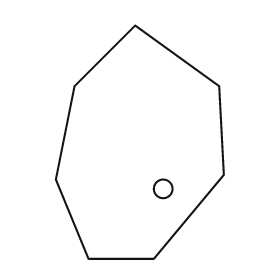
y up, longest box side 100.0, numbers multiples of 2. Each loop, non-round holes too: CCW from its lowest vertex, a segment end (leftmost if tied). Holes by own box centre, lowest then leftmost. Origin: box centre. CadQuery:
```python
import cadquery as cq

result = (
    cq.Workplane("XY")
    .moveTo(-22.0, -50.0)
    .lineTo(6.0, -50.0)
    .lineTo(36.0, -14.0)
    .lineTo(34.0, 24.0)
    .lineTo(-2.0, 50.0)
    .lineTo(-28.0, 24.0)
    .lineTo(-36.0, -16.0)
    .close()
    .moveTo(10.0, -20.0)
    .circle(4.0)
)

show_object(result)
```